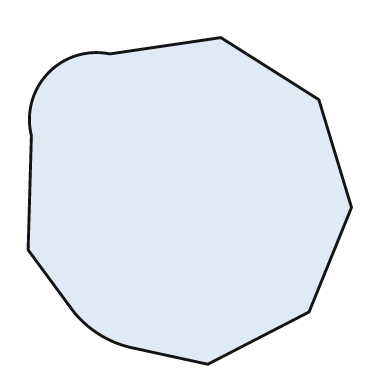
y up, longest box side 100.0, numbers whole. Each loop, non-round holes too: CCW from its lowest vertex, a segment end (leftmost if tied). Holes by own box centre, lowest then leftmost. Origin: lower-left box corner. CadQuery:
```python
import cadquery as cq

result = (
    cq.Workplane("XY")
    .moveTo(55.0, 0.0)
    .lineTo(86.0, 16.0)
    .lineTo(99.0, 48.0)
    .lineTo(89.0, 81.0)
    .lineTo(59.0, 100.0)
    .lineTo(25.0, 95.0)
    .threePointArc((6.0, 89.0), (1.0, 70.0))
    .lineTo(0.0, 35.0)
    .lineTo(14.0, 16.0)
    .threePointArc((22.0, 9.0), (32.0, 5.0))
    .close()
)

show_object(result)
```